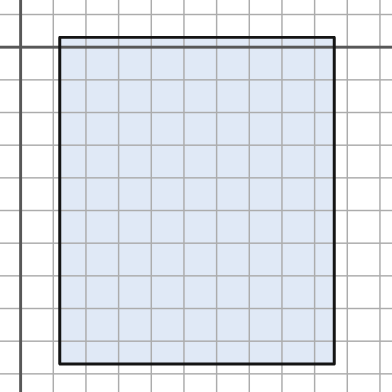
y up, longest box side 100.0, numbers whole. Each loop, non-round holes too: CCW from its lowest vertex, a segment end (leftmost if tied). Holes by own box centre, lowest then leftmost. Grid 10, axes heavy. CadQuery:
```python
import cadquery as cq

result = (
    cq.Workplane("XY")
    .moveTo(12.0, -97.0)
    .lineTo(96.0, -97.0)
    .lineTo(96.0, 3.0)
    .lineTo(12.0, 3.0)
    .close()
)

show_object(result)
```